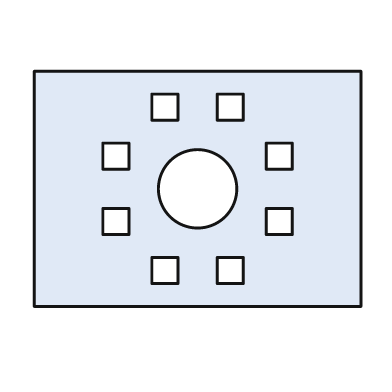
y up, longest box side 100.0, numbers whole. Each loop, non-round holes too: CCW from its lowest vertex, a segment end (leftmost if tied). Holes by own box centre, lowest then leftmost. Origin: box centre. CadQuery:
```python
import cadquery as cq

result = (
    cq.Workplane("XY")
    .moveTo(-50.0, -36.0)
    .lineTo(50.0, -36.0)
    .lineTo(50.0, 36.0)
    .lineTo(-50.0, 36.0)
    .close()
    .moveTo(-14.0, -29.0)
    .lineTo(-6.0, -29.0)
    .lineTo(-6.0, -21.0)
    .lineTo(-14.0, -21.0)
    .close()
    .moveTo(6.0, -29.0)
    .lineTo(14.0, -29.0)
    .lineTo(14.0, -21.0)
    .lineTo(6.0, -21.0)
    .close()
    .moveTo(-29.0, -14.0)
    .lineTo(-21.0, -14.0)
    .lineTo(-21.0, -6.0)
    .lineTo(-29.0, -6.0)
    .close()
    .moveTo(21.0, -14.0)
    .lineTo(29.0, -14.0)
    .lineTo(29.0, -6.0)
    .lineTo(21.0, -6.0)
    .close()
    .moveTo(0.0, 0.0)
    .circle(12.0)
    .moveTo(-29.0, 6.0)
    .lineTo(-21.0, 6.0)
    .lineTo(-21.0, 14.0)
    .lineTo(-29.0, 14.0)
    .close()
    .moveTo(21.0, 6.0)
    .lineTo(29.0, 6.0)
    .lineTo(29.0, 14.0)
    .lineTo(21.0, 14.0)
    .close()
    .moveTo(-14.0, 21.0)
    .lineTo(-6.0, 21.0)
    .lineTo(-6.0, 29.0)
    .lineTo(-14.0, 29.0)
    .close()
    .moveTo(6.0, 21.0)
    .lineTo(14.0, 21.0)
    .lineTo(14.0, 29.0)
    .lineTo(6.0, 29.0)
    .close()
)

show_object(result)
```